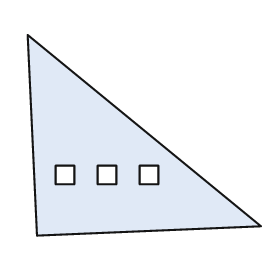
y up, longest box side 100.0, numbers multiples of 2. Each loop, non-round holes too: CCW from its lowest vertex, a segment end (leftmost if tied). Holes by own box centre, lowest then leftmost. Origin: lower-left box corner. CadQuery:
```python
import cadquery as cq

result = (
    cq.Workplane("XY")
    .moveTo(4.0, 0.0)
    .lineTo(100.0, 4.0)
    .lineTo(0.0, 86.0)
    .close()
    .moveTo(12.0, 22.0)
    .lineTo(20.0, 22.0)
    .lineTo(20.0, 30.0)
    .lineTo(12.0, 30.0)
    .close()
    .moveTo(30.0, 22.0)
    .lineTo(38.0, 22.0)
    .lineTo(38.0, 30.0)
    .lineTo(30.0, 30.0)
    .close()
    .moveTo(48.0, 22.0)
    .lineTo(56.0, 22.0)
    .lineTo(56.0, 30.0)
    .lineTo(48.0, 30.0)
    .close()
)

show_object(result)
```